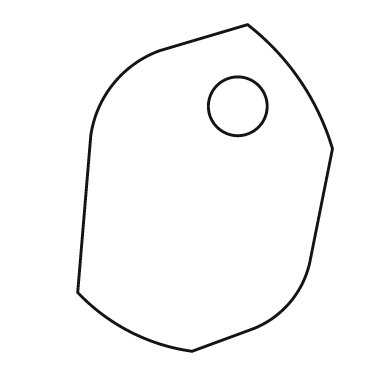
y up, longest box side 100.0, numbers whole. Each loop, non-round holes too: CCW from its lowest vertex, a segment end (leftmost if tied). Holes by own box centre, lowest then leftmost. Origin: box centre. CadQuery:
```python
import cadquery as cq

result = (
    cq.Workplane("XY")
    .moveTo(-4.0, -50.0)
    .lineTo(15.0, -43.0)
    .threePointArc((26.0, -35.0), (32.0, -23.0))
    .lineTo(39.0, 12.0)
    .threePointArc((29.0, 33.0), (13.0, 50.0))
    .lineTo(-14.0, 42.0)
    .threePointArc((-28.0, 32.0), (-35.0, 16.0))
    .lineTo(-39.0, -32.0)
    .threePointArc((-23.0, -44.0), (-4.0, -50.0))
    .close()
    .moveTo(10.0, 25.0)
    .circle(9.0)
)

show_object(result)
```